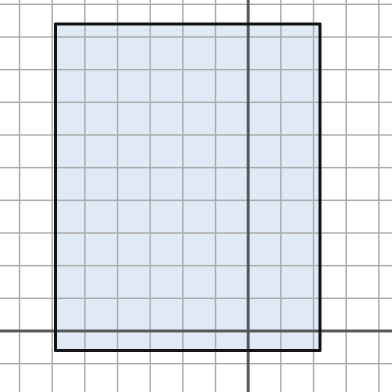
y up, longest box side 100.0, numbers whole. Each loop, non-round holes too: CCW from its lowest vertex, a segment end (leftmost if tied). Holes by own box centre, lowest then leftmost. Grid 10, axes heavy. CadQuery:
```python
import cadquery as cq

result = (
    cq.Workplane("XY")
    .moveTo(-59.0, -6.0)
    .lineTo(22.0, -6.0)
    .lineTo(22.0, 94.0)
    .lineTo(-59.0, 94.0)
    .close()
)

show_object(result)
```